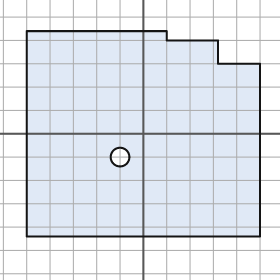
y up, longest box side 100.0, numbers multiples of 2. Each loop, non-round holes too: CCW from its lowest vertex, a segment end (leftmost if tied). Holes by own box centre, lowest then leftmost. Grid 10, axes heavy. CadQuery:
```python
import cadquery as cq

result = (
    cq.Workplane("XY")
    .moveTo(-50.0, -44.0)
    .lineTo(50.0, -44.0)
    .lineTo(50.0, 30.0)
    .lineTo(32.0, 30.0)
    .lineTo(32.0, 40.0)
    .lineTo(10.0, 40.0)
    .lineTo(10.0, 44.0)
    .lineTo(-50.0, 44.0)
    .close()
    .moveTo(-10.0, -10.0)
    .circle(4.0)
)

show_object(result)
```